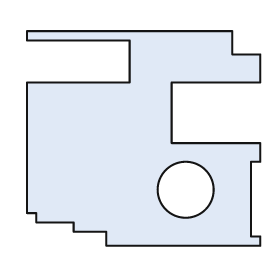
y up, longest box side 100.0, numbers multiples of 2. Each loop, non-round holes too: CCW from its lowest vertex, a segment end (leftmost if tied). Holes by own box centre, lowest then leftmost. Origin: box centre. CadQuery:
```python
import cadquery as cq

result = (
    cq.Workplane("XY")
    .moveTo(-16.0, -46.0)
    .lineTo(50.0, -46.0)
    .lineTo(50.0, -42.0)
    .lineTo(46.0, -42.0)
    .lineTo(46.0, -10.0)
    .lineTo(50.0, -10.0)
    .lineTo(50.0, -2.0)
    .lineTo(12.0, -2.0)
    .lineTo(12.0, 24.0)
    .lineTo(50.0, 24.0)
    .lineTo(50.0, 36.0)
    .lineTo(38.0, 36.0)
    .lineTo(38.0, 46.0)
    .lineTo(-50.0, 46.0)
    .lineTo(-50.0, 42.0)
    .lineTo(-6.0, 42.0)
    .lineTo(-6.0, 24.0)
    .lineTo(-50.0, 24.0)
    .lineTo(-50.0, -32.0)
    .lineTo(-46.0, -32.0)
    .lineTo(-46.0, -36.0)
    .lineTo(-30.0, -36.0)
    .lineTo(-30.0, -40.0)
    .lineTo(-16.0, -40.0)
    .close()
    .moveTo(18.0, -22.0)
    .circle(12.0)
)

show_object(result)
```